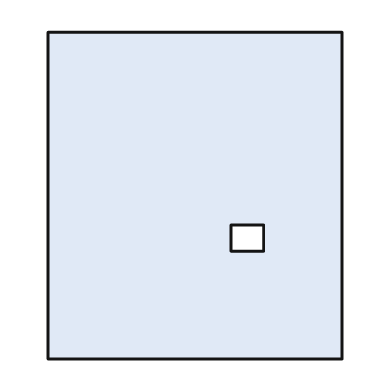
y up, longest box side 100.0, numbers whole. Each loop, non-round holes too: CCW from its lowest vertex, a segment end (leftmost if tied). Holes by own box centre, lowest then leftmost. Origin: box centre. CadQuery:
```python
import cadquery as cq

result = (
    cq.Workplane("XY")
    .moveTo(-45.0, -50.0)
    .lineTo(45.0, -50.0)
    .lineTo(45.0, 50.0)
    .lineTo(-45.0, 50.0)
    .close()
    .moveTo(11.0, -17.0)
    .lineTo(21.0, -17.0)
    .lineTo(21.0, -9.0)
    .lineTo(11.0, -9.0)
    .close()
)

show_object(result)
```